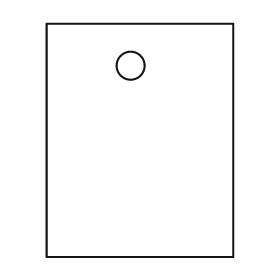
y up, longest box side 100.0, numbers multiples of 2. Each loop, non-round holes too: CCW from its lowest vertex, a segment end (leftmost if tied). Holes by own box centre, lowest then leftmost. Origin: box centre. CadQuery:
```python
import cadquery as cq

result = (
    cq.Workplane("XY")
    .moveTo(-40.0, -50.0)
    .lineTo(40.0, -50.0)
    .lineTo(40.0, 50.0)
    .lineTo(-40.0, 50.0)
    .close()
    .moveTo(-4.0, 32.0)
    .circle(6.0)
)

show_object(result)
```